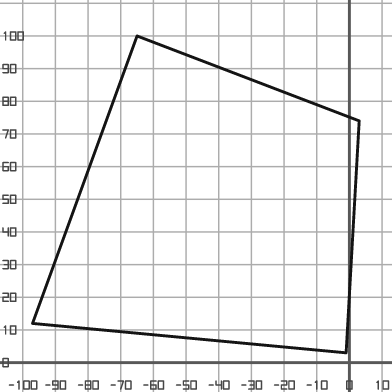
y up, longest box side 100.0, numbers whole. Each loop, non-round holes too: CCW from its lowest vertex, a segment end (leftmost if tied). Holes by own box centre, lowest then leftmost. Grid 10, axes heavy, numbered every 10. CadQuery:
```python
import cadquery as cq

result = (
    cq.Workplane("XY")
    .moveTo(-1.0, 3.0)
    .lineTo(3.0, 74.0)
    .lineTo(-65.0, 100.0)
    .lineTo(-97.0, 12.0)
    .close()
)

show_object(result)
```